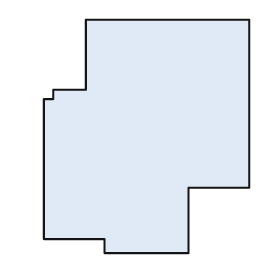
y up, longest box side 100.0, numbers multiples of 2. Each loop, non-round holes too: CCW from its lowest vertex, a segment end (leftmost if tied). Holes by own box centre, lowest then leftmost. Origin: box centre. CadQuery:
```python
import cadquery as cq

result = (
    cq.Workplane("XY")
    .moveTo(-18.0, -50.0)
    .lineTo(18.0, -50.0)
    .lineTo(18.0, -22.0)
    .lineTo(44.0, -22.0)
    .lineTo(44.0, 50.0)
    .lineTo(-26.0, 50.0)
    .lineTo(-26.0, 20.0)
    .lineTo(-40.0, 20.0)
    .lineTo(-40.0, 16.0)
    .lineTo(-44.0, 16.0)
    .lineTo(-44.0, -44.0)
    .lineTo(-18.0, -44.0)
    .close()
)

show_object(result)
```